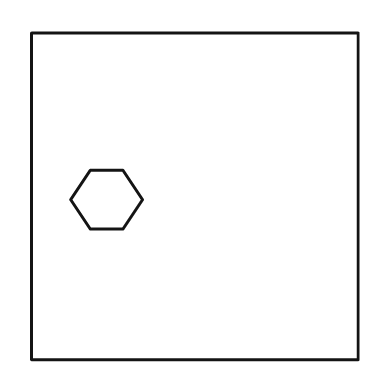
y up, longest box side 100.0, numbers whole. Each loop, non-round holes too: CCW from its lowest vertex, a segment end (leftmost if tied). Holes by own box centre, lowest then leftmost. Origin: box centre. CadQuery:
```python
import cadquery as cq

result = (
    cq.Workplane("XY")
    .moveTo(-50.0, -50.0)
    .lineTo(50.0, -50.0)
    .lineTo(50.0, 50.0)
    .lineTo(-50.0, 50.0)
    .close()
    .moveTo(-32.0, -10.0)
    .lineTo(-22.0, -10.0)
    .lineTo(-16.0, -1.0)
    .lineTo(-22.0, 8.0)
    .lineTo(-32.0, 8.0)
    .lineTo(-38.0, -1.0)
    .close()
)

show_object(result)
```